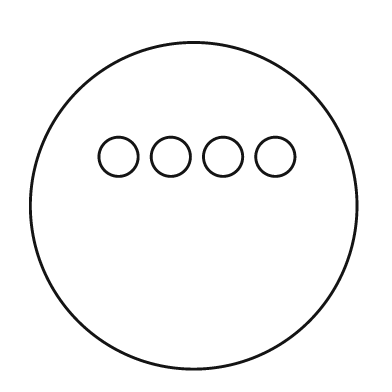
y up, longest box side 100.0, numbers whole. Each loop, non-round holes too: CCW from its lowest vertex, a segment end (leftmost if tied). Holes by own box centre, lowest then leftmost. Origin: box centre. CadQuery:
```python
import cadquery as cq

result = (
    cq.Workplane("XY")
    .moveTo(0.0, 0.0)
    .circle(50.0)
    .moveTo(-23.0, 15.0)
    .circle(6.0)
    .moveTo(-7.0, 15.0)
    .circle(6.0)
    .moveTo(9.0, 15.0)
    .circle(6.0)
    .moveTo(25.0, 15.0)
    .circle(6.0)
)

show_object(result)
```